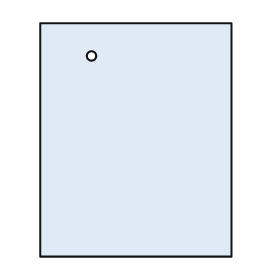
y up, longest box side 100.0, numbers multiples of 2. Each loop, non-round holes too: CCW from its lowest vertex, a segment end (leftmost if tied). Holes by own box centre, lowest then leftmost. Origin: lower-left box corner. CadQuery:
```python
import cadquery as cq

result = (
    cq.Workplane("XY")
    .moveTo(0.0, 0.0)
    .lineTo(82.0, 0.0)
    .lineTo(82.0, 100.0)
    .lineTo(0.0, 100.0)
    .close()
    .moveTo(22.0, 86.0)
    .circle(2.0)
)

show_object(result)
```